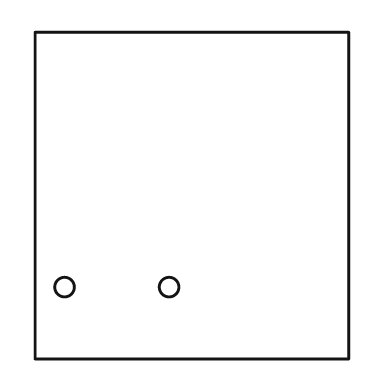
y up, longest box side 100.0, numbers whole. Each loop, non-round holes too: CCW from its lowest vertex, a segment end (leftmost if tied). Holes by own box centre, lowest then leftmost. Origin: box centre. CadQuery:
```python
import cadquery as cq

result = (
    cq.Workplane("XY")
    .moveTo(-48.0, -50.0)
    .lineTo(48.0, -50.0)
    .lineTo(48.0, 50.0)
    .lineTo(-48.0, 50.0)
    .close()
    .moveTo(-39.0, -28.0)
    .circle(3.0)
    .moveTo(-7.0, -28.0)
    .circle(3.0)
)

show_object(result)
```